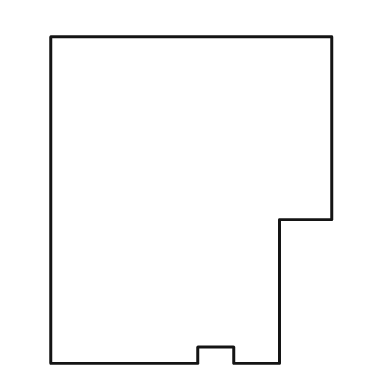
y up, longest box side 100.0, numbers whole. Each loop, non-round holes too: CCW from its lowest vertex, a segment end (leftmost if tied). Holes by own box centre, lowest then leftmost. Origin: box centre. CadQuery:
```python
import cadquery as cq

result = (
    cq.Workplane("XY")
    .moveTo(-43.0, -50.0)
    .lineTo(2.0, -50.0)
    .lineTo(2.0, -45.0)
    .lineTo(13.0, -45.0)
    .lineTo(13.0, -50.0)
    .lineTo(27.0, -50.0)
    .lineTo(27.0, -6.0)
    .lineTo(43.0, -6.0)
    .lineTo(43.0, 50.0)
    .lineTo(-43.0, 50.0)
    .close()
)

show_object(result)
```